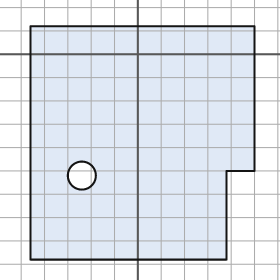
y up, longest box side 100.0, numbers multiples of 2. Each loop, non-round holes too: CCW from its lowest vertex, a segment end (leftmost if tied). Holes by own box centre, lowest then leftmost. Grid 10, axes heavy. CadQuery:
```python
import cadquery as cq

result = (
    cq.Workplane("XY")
    .moveTo(-46.0, -88.0)
    .lineTo(38.0, -88.0)
    .lineTo(38.0, -50.0)
    .lineTo(50.0, -50.0)
    .lineTo(50.0, 12.0)
    .lineTo(-46.0, 12.0)
    .close()
    .moveTo(-24.0, -52.0)
    .circle(6.0)
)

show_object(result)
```